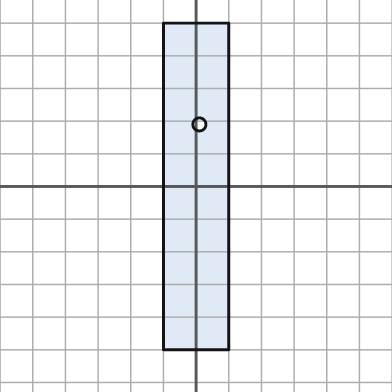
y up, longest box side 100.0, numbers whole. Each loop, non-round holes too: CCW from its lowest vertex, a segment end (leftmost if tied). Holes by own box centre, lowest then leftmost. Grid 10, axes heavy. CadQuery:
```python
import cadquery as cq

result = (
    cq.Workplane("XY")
    .moveTo(-10.0, -50.0)
    .lineTo(10.0, -50.0)
    .lineTo(10.0, 50.0)
    .lineTo(-10.0, 50.0)
    .close()
    .moveTo(1.0, 19.0)
    .circle(2.0)
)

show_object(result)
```